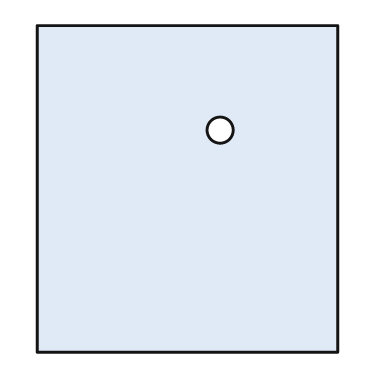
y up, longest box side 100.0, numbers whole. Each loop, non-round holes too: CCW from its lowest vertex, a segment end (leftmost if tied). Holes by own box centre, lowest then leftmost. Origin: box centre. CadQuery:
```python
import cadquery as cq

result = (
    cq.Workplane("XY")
    .moveTo(-46.0, -50.0)
    .lineTo(46.0, -50.0)
    .lineTo(46.0, 50.0)
    .lineTo(-46.0, 50.0)
    .close()
    .moveTo(10.0, 18.0)
    .circle(4.0)
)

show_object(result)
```